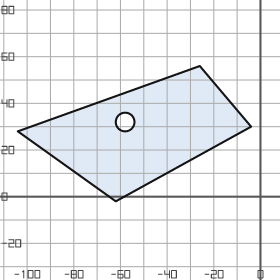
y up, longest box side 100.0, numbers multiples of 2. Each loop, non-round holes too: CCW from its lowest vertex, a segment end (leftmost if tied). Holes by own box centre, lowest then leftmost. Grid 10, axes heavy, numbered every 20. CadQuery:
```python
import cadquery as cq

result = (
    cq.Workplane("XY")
    .moveTo(-62.0, -2.0)
    .lineTo(-4.0, 30.0)
    .lineTo(-26.0, 56.0)
    .lineTo(-104.0, 28.0)
    .close()
    .moveTo(-58.0, 32.0)
    .circle(4.0)
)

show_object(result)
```